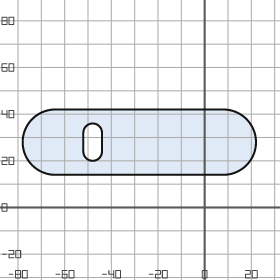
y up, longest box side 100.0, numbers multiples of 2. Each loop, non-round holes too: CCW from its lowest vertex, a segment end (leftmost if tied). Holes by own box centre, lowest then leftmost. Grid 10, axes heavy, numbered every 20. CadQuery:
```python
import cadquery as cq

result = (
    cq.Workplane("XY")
    .moveTo(-64.0, 14.0)
    .lineTo(8.0, 14.0)
    .threePointArc((22.0, 28.0), (8.0, 42.0))
    .lineTo(-64.0, 42.0)
    .threePointArc((-78.0, 28.0), (-64.0, 14.0))
    .close()
    .moveTo(-52.0, 24.0)
    .threePointArc((-48.0, 20.0), (-44.0, 24.0))
    .lineTo(-44.0, 32.0)
    .threePointArc((-48.0, 36.0), (-52.0, 32.0))
    .close()
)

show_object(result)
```